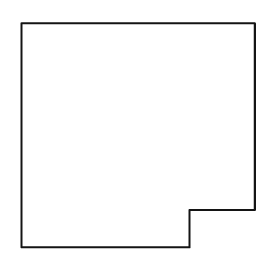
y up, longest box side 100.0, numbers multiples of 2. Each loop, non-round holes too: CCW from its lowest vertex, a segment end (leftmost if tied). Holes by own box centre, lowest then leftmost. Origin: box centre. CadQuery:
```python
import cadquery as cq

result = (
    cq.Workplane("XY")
    .moveTo(-50.0, -48.0)
    .lineTo(22.0, -48.0)
    .lineTo(22.0, -32.0)
    .lineTo(50.0, -32.0)
    .lineTo(50.0, 48.0)
    .lineTo(-50.0, 48.0)
    .close()
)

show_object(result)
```